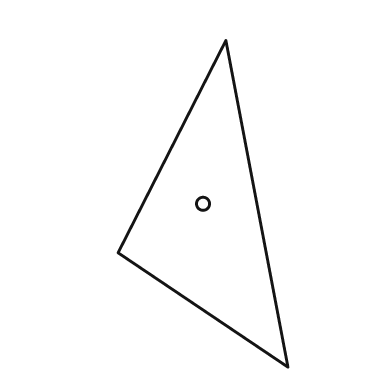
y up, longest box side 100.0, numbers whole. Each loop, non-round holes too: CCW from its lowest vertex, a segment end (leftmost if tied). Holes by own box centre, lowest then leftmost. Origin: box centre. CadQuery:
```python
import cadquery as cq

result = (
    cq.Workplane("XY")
    .moveTo(26.0, -50.0)
    .lineTo(7.0, 50.0)
    .lineTo(-26.0, -15.0)
    .close()
    .moveTo(0.0, 0.0)
    .circle(2.0)
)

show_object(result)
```